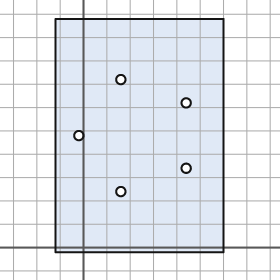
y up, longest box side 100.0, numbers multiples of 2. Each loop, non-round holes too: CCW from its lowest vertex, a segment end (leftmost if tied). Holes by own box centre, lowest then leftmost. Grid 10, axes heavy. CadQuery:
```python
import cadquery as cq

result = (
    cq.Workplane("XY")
    .moveTo(-12.0, -2.0)
    .lineTo(60.0, -2.0)
    .lineTo(60.0, 98.0)
    .lineTo(-12.0, 98.0)
    .close()
    .moveTo(16.0, 24.0)
    .circle(2.0)
    .moveTo(44.0, 34.0)
    .circle(2.0)
    .moveTo(-2.0, 48.0)
    .circle(2.0)
    .moveTo(44.0, 62.0)
    .circle(2.0)
    .moveTo(16.0, 72.0)
    .circle(2.0)
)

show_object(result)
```